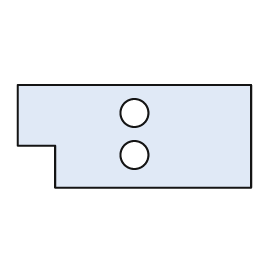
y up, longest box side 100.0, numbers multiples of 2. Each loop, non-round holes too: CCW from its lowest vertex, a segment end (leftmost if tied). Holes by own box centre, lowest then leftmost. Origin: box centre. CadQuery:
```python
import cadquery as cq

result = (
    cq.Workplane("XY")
    .moveTo(-34.0, -22.0)
    .lineTo(50.0, -22.0)
    .lineTo(50.0, 22.0)
    .lineTo(-50.0, 22.0)
    .lineTo(-50.0, -4.0)
    .lineTo(-34.0, -4.0)
    .close()
    .moveTo(0.0, -8.0)
    .circle(6.0)
    .moveTo(0.0, 10.0)
    .circle(6.0)
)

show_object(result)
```